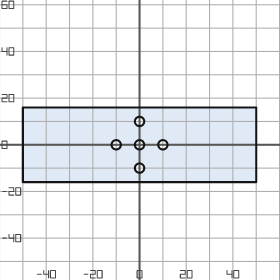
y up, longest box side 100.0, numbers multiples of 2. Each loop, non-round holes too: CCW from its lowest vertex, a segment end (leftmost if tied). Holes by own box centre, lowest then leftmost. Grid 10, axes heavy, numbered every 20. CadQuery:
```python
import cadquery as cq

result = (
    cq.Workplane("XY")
    .moveTo(-50.0, -16.0)
    .lineTo(50.0, -16.0)
    .lineTo(50.0, 16.0)
    .lineTo(-50.0, 16.0)
    .close()
    .moveTo(0.0, -10.0)
    .circle(2.0)
    .moveTo(-10.0, 0.0)
    .circle(2.0)
    .moveTo(0.0, 0.0)
    .circle(2.0)
    .moveTo(10.0, 0.0)
    .circle(2.0)
    .moveTo(0.0, 10.0)
    .circle(2.0)
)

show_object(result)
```